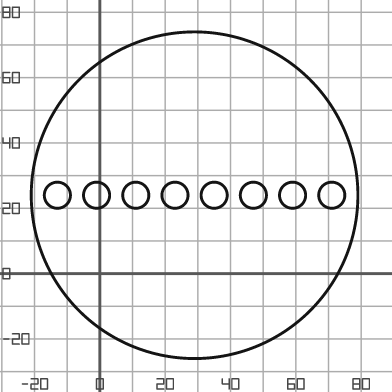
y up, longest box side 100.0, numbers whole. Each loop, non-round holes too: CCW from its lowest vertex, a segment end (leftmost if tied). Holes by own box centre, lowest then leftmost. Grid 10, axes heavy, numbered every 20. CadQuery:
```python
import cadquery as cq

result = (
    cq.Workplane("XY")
    .moveTo(29.0, 24.0)
    .circle(50.0)
    .moveTo(-13.0, 24.0)
    .circle(4.0)
    .moveTo(-1.0, 24.0)
    .circle(4.0)
    .moveTo(11.0, 24.0)
    .circle(4.0)
    .moveTo(23.0, 24.0)
    .circle(4.0)
    .moveTo(35.0, 24.0)
    .circle(4.0)
    .moveTo(47.0, 24.0)
    .circle(4.0)
    .moveTo(59.0, 24.0)
    .circle(4.0)
    .moveTo(71.0, 24.0)
    .circle(4.0)
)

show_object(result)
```